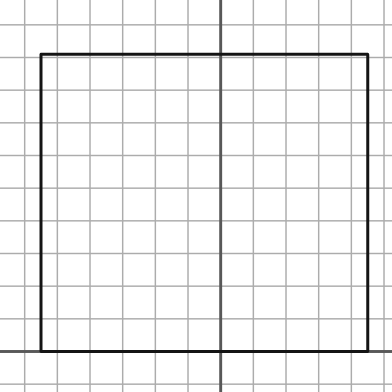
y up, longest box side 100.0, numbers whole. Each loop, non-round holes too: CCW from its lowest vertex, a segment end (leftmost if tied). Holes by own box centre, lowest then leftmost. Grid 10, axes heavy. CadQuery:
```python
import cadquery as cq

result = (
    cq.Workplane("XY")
    .moveTo(-55.0, 0.0)
    .lineTo(45.0, 0.0)
    .lineTo(45.0, 91.0)
    .lineTo(-55.0, 91.0)
    .close()
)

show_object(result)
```